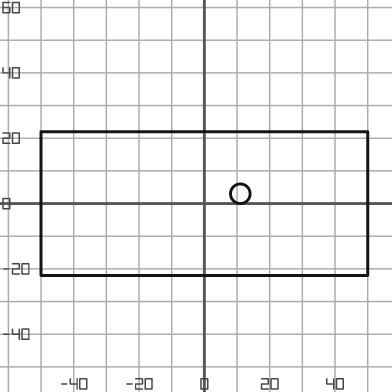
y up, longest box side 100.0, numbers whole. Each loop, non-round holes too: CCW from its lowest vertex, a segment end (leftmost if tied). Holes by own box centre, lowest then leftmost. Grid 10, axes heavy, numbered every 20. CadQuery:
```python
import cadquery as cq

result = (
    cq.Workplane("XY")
    .moveTo(-50.0, -22.0)
    .lineTo(50.0, -22.0)
    .lineTo(50.0, 22.0)
    .lineTo(-50.0, 22.0)
    .close()
    .moveTo(11.0, 3.0)
    .circle(3.0)
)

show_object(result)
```